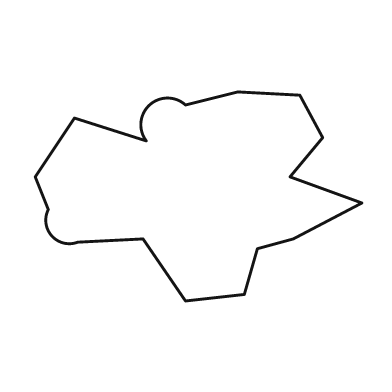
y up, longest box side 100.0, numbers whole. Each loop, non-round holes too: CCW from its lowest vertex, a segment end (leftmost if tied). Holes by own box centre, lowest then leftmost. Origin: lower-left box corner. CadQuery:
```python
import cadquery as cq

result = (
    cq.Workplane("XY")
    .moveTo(46.0, 0.0)
    .lineTo(64.0, 2.0)
    .lineTo(68.0, 16.0)
    .lineTo(79.0, 19.0)
    .lineTo(100.0, 30.0)
    .lineTo(78.0, 38.0)
    .lineTo(88.0, 50.0)
    .lineTo(81.0, 63.0)
    .lineTo(62.0, 64.0)
    .lineTo(46.0, 60.0)
    .threePointArc((35.0, 60.0), (34.0, 49.0))
    .lineTo(12.0, 56.0)
    .lineTo(0.0, 38.0)
    .lineTo(4.0, 28.0)
    .threePointArc((5.0, 20.0), (13.0, 18.0))
    .lineTo(33.0, 19.0)
    .close()
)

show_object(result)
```